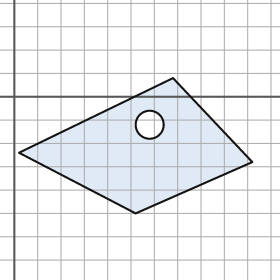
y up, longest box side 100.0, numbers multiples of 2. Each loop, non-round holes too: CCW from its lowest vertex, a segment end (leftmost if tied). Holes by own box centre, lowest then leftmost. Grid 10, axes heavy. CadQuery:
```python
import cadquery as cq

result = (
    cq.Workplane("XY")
    .moveTo(52.0, -50.0)
    .lineTo(102.0, -28.0)
    .lineTo(68.0, 8.0)
    .lineTo(2.0, -24.0)
    .close()
    .moveTo(58.0, -12.0)
    .circle(6.0)
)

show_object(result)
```